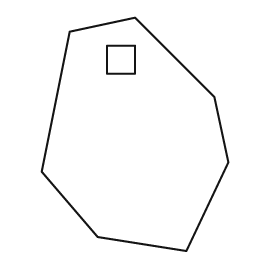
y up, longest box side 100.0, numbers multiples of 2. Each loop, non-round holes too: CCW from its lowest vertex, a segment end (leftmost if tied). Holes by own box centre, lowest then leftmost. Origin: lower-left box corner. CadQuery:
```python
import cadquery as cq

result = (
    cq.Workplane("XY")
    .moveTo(62.0, 0.0)
    .lineTo(80.0, 38.0)
    .lineTo(74.0, 66.0)
    .lineTo(40.0, 100.0)
    .lineTo(12.0, 94.0)
    .lineTo(0.0, 34.0)
    .lineTo(24.0, 6.0)
    .close()
    .moveTo(28.0, 76.0)
    .lineTo(40.0, 76.0)
    .lineTo(40.0, 88.0)
    .lineTo(28.0, 88.0)
    .close()
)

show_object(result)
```